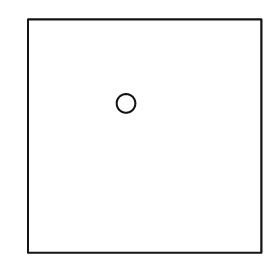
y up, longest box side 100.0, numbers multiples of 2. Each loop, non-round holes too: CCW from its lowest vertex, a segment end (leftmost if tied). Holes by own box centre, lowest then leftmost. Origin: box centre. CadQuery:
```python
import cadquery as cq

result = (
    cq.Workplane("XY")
    .moveTo(-50.0, -50.0)
    .lineTo(50.0, -50.0)
    .lineTo(50.0, 50.0)
    .lineTo(-50.0, 50.0)
    .close()
    .moveTo(-8.0, 14.0)
    .circle(4.0)
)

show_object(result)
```